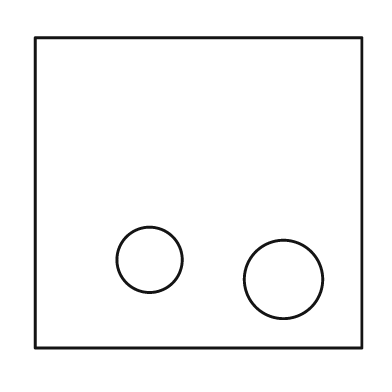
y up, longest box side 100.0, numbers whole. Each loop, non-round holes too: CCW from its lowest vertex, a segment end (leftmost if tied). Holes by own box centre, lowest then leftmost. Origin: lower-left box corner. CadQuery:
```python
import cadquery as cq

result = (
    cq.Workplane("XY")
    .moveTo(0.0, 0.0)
    .lineTo(100.0, 0.0)
    .lineTo(100.0, 95.0)
    .lineTo(0.0, 95.0)
    .close()
    .moveTo(76.0, 21.0)
    .circle(12.0)
    .moveTo(35.0, 27.0)
    .circle(10.0)
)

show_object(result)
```